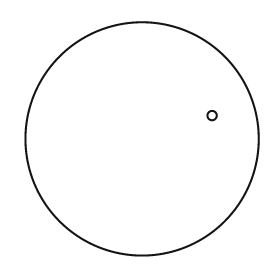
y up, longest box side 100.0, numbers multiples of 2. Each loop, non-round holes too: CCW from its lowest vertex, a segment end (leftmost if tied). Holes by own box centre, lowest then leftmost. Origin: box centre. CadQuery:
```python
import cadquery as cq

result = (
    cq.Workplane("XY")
    .moveTo(0.0, 0.0)
    .circle(50.0)
    .moveTo(30.0, 10.0)
    .circle(2.0)
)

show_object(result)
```